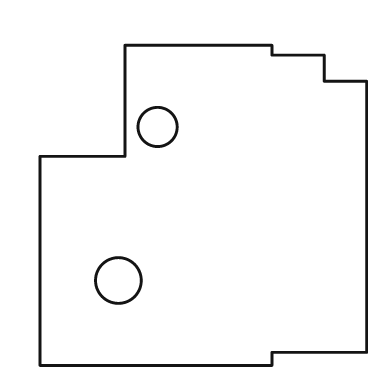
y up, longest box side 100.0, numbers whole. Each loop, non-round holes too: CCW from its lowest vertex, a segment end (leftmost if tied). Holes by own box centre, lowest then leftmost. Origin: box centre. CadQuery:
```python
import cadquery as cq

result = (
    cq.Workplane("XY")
    .moveTo(-50.0, -49.0)
    .lineTo(21.0, -49.0)
    .lineTo(21.0, -45.0)
    .lineTo(50.0, -45.0)
    .lineTo(50.0, 38.0)
    .lineTo(37.0, 38.0)
    .lineTo(37.0, 46.0)
    .lineTo(21.0, 46.0)
    .lineTo(21.0, 49.0)
    .lineTo(-24.0, 49.0)
    .lineTo(-24.0, 15.0)
    .lineTo(-50.0, 15.0)
    .close()
    .moveTo(-26.0, -23.0)
    .circle(7.0)
    .moveTo(-14.0, 24.0)
    .circle(6.0)
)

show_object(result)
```